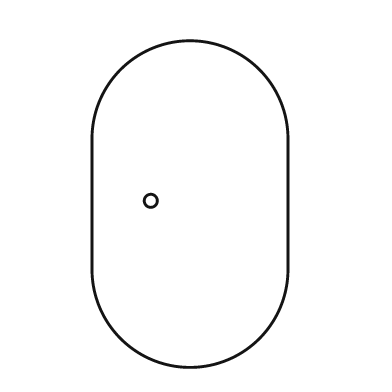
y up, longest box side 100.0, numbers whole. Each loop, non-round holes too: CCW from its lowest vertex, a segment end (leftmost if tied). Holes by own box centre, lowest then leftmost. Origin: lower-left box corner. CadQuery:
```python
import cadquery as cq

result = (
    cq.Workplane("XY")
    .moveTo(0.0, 30.0)
    .threePointArc((30.0, 0.0), (60.0, 30.0))
    .lineTo(60.0, 70.0)
    .threePointArc((30.0, 100.0), (0.0, 70.0))
    .close()
    .moveTo(18.0, 51.0)
    .circle(2.0)
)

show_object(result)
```